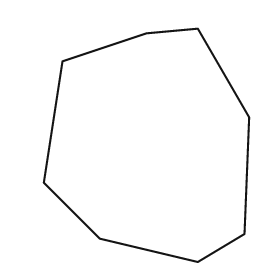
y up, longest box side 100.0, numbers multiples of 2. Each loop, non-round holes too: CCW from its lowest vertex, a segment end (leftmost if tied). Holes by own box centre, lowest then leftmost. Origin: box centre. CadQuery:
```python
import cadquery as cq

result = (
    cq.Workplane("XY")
    .moveTo(22.0, -50.0)
    .lineTo(42.0, -38.0)
    .lineTo(44.0, 12.0)
    .lineTo(22.0, 50.0)
    .lineTo(0.0, 48.0)
    .lineTo(-36.0, 36.0)
    .lineTo(-44.0, -16.0)
    .lineTo(-20.0, -40.0)
    .close()
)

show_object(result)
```